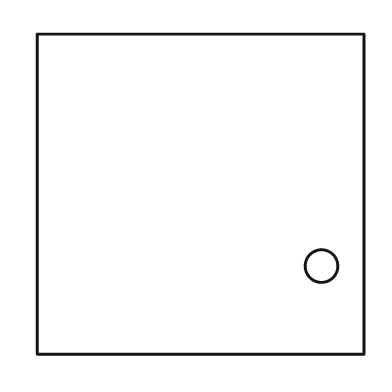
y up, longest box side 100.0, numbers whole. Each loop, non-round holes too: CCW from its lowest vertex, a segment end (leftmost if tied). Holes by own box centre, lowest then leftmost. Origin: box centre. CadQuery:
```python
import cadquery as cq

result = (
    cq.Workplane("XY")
    .moveTo(-50.0, -49.0)
    .lineTo(50.0, -49.0)
    .lineTo(50.0, 49.0)
    .lineTo(-50.0, 49.0)
    .close()
    .moveTo(37.0, -22.0)
    .circle(5.0)
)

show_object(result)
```